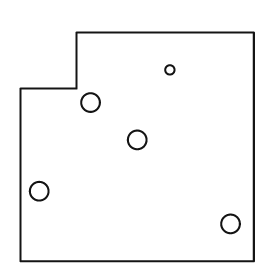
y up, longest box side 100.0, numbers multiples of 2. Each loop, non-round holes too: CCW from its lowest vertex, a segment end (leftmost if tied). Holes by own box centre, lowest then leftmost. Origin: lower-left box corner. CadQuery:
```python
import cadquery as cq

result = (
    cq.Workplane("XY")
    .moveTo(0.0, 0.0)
    .lineTo(100.0, 0.0)
    .lineTo(100.0, 98.0)
    .lineTo(24.0, 98.0)
    .lineTo(24.0, 74.0)
    .lineTo(0.0, 74.0)
    .close()
    .moveTo(90.0, 16.0)
    .circle(4.0)
    .moveTo(8.0, 30.0)
    .circle(4.0)
    .moveTo(50.0, 52.0)
    .circle(4.0)
    .moveTo(30.0, 68.0)
    .circle(4.0)
    .moveTo(64.0, 82.0)
    .circle(2.0)
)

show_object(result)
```